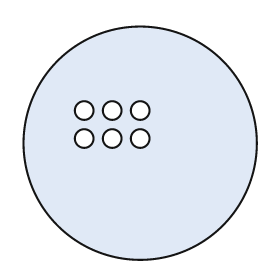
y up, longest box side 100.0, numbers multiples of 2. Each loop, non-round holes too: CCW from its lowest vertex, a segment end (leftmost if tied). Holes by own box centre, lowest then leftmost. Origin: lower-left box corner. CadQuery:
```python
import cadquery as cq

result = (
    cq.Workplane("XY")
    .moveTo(50.0, 50.0)
    .circle(50.0)
    .moveTo(26.0, 52.0)
    .circle(4.0)
    .moveTo(38.0, 52.0)
    .circle(4.0)
    .moveTo(50.0, 52.0)
    .circle(4.0)
    .moveTo(26.0, 64.0)
    .circle(4.0)
    .moveTo(38.0, 64.0)
    .circle(4.0)
    .moveTo(50.0, 64.0)
    .circle(4.0)
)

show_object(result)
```